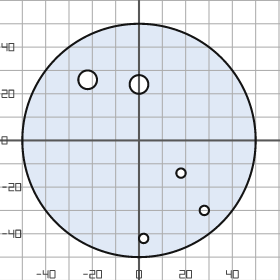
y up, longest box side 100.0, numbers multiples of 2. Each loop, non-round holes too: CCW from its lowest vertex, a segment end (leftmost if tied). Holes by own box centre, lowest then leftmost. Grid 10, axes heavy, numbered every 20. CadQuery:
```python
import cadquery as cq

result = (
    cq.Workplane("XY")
    .moveTo(0.0, 0.0)
    .circle(50.0)
    .moveTo(2.0, -42.0)
    .circle(2.0)
    .moveTo(28.0, -30.0)
    .circle(2.0)
    .moveTo(18.0, -14.0)
    .circle(2.0)
    .moveTo(0.0, 24.0)
    .circle(4.0)
    .moveTo(-22.0, 26.0)
    .circle(4.0)
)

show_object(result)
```